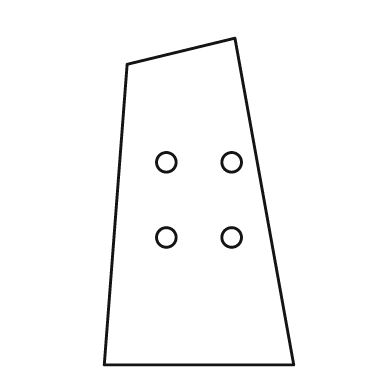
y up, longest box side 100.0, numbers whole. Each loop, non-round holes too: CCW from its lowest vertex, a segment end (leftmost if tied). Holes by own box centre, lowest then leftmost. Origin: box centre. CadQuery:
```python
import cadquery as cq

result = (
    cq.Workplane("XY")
    .moveTo(-29.0, -50.0)
    .lineTo(29.0, -50.0)
    .lineTo(11.0, 50.0)
    .lineTo(-22.0, 42.0)
    .close()
    .moveTo(-10.0, -11.0)
    .circle(3.0)
    .moveTo(10.0, -11.0)
    .circle(3.0)
    .moveTo(-10.0, 12.0)
    .circle(3.0)
    .moveTo(10.0, 12.0)
    .circle(3.0)
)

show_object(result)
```